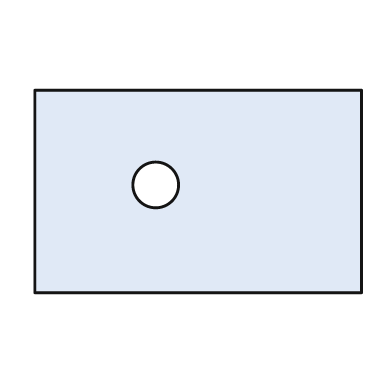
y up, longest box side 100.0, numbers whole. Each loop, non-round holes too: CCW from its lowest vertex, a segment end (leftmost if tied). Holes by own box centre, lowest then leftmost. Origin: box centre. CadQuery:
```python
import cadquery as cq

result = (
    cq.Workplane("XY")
    .moveTo(-50.0, -31.0)
    .lineTo(50.0, -31.0)
    .lineTo(50.0, 31.0)
    .lineTo(-50.0, 31.0)
    .close()
    .moveTo(-13.0, 2.0)
    .circle(7.0)
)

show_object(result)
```